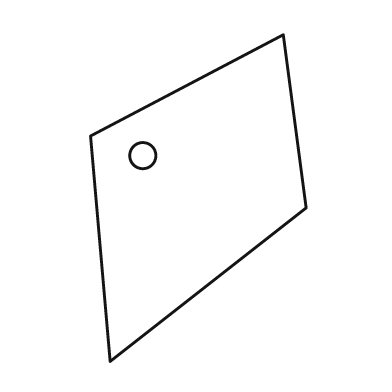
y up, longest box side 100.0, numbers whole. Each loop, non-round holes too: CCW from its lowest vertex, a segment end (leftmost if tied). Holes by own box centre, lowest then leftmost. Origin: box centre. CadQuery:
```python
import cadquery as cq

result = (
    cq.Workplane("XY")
    .moveTo(-27.0, -50.0)
    .lineTo(33.0, -3.0)
    .lineTo(26.0, 50.0)
    .lineTo(-33.0, 19.0)
    .close()
    .moveTo(-17.0, 13.0)
    .circle(4.0)
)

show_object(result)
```